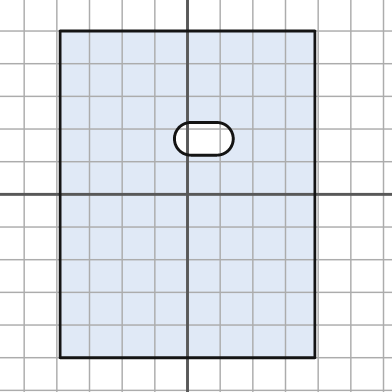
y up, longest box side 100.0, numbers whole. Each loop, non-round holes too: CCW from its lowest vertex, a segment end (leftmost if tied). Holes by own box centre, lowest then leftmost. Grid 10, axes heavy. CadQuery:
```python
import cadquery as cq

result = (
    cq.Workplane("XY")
    .moveTo(-39.0, -50.0)
    .lineTo(39.0, -50.0)
    .lineTo(39.0, 50.0)
    .lineTo(-39.0, 50.0)
    .close()
    .moveTo(1.0, 12.0)
    .lineTo(9.0, 12.0)
    .threePointArc((14.0, 17.0), (9.0, 22.0))
    .lineTo(1.0, 22.0)
    .threePointArc((-4.0, 17.0), (1.0, 12.0))
    .close()
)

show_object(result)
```